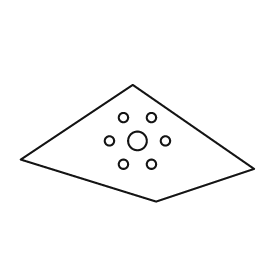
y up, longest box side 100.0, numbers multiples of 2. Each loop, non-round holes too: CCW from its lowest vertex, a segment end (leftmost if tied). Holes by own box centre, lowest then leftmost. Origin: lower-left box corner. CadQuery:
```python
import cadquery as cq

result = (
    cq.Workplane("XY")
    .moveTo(58.0, 0.0)
    .lineTo(100.0, 14.0)
    .lineTo(48.0, 50.0)
    .lineTo(0.0, 18.0)
    .close()
    .moveTo(44.0, 16.0)
    .circle(2.0)
    .moveTo(56.0, 16.0)
    .circle(2.0)
    .moveTo(38.0, 26.0)
    .circle(2.0)
    .moveTo(50.0, 26.0)
    .circle(4.0)
    .moveTo(62.0, 26.0)
    .circle(2.0)
    .moveTo(44.0, 36.0)
    .circle(2.0)
    .moveTo(56.0, 36.0)
    .circle(2.0)
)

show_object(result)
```